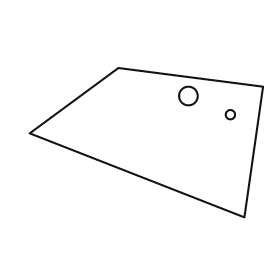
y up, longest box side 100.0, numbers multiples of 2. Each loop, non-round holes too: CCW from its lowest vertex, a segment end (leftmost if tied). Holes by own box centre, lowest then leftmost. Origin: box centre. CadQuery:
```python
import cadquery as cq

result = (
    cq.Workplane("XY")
    .moveTo(42.0, -32.0)
    .lineTo(50.0, 24.0)
    .lineTo(-12.0, 32.0)
    .lineTo(-50.0, 4.0)
    .close()
    .moveTo(36.0, 12.0)
    .circle(2.0)
    .moveTo(18.0, 20.0)
    .circle(4.0)
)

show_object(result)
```